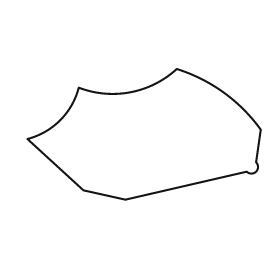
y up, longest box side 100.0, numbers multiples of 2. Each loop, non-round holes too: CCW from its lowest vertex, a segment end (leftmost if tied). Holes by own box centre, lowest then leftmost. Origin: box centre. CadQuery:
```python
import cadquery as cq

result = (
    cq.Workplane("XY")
    .moveTo(-8.0, -28.0)
    .lineTo(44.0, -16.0)
    .threePointArc((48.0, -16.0), (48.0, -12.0))
    .lineTo(50.0, 2.0)
    .threePointArc((34.0, 18.0), (14.0, 28.0))
    .threePointArc((-6.0, 18.0), (-28.0, 20.0))
    .threePointArc((-36.0, 6.0), (-50.0, -2.0))
    .lineTo(-26.0, -24.0)
    .close()
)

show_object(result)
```